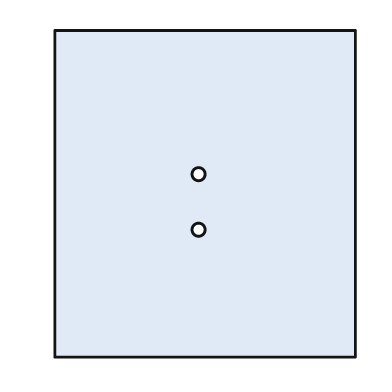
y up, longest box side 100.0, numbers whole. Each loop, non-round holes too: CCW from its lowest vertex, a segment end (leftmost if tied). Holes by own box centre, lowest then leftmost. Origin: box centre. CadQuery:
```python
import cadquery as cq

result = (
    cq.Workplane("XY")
    .moveTo(-46.0, -50.0)
    .lineTo(46.0, -50.0)
    .lineTo(46.0, 50.0)
    .lineTo(-46.0, 50.0)
    .close()
    .moveTo(-2.0, -11.0)
    .circle(2.0)
    .moveTo(-2.0, 6.0)
    .circle(2.0)
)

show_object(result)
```